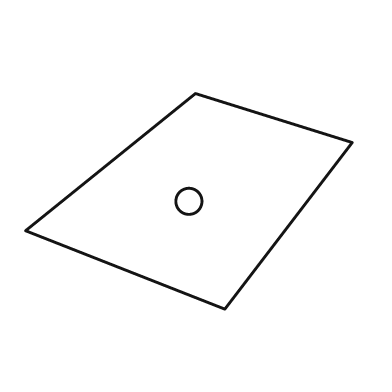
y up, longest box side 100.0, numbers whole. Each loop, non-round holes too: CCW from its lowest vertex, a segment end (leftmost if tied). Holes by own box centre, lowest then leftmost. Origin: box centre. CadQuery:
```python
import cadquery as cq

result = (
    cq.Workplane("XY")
    .moveTo(11.0, -33.0)
    .lineTo(50.0, 18.0)
    .lineTo(2.0, 33.0)
    .lineTo(-50.0, -9.0)
    .close()
    .moveTo(0.0, 0.0)
    .circle(4.0)
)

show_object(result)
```